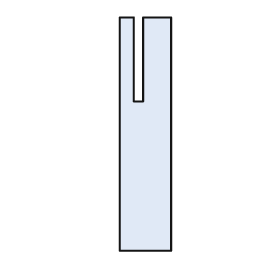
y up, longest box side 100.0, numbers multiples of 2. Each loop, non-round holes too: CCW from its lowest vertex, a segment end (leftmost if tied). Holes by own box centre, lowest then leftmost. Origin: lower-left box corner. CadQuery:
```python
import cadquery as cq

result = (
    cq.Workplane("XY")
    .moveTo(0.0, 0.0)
    .lineTo(22.0, 0.0)
    .lineTo(22.0, 100.0)
    .lineTo(10.0, 100.0)
    .lineTo(10.0, 64.0)
    .lineTo(6.0, 64.0)
    .lineTo(6.0, 100.0)
    .lineTo(0.0, 100.0)
    .close()
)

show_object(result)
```